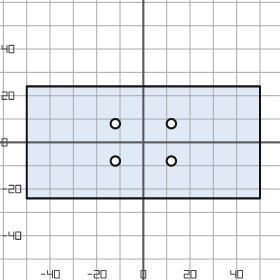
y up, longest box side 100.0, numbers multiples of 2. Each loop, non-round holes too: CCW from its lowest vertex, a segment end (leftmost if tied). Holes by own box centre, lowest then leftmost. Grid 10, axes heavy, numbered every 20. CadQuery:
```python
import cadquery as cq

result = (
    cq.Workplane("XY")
    .moveTo(-50.0, -24.0)
    .lineTo(50.0, -24.0)
    .lineTo(50.0, 24.0)
    .lineTo(-50.0, 24.0)
    .close()
    .moveTo(-12.0, -8.0)
    .circle(2.0)
    .moveTo(12.0, -8.0)
    .circle(2.0)
    .moveTo(-12.0, 8.0)
    .circle(2.0)
    .moveTo(12.0, 8.0)
    .circle(2.0)
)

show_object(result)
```